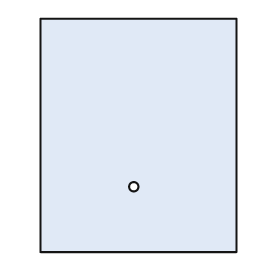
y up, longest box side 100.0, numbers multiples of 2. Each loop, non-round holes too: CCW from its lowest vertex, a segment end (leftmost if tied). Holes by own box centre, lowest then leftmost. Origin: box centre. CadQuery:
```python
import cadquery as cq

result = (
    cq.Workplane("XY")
    .moveTo(-42.0, -50.0)
    .lineTo(42.0, -50.0)
    .lineTo(42.0, 50.0)
    .lineTo(-42.0, 50.0)
    .close()
    .moveTo(-2.0, -22.0)
    .circle(2.0)
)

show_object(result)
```